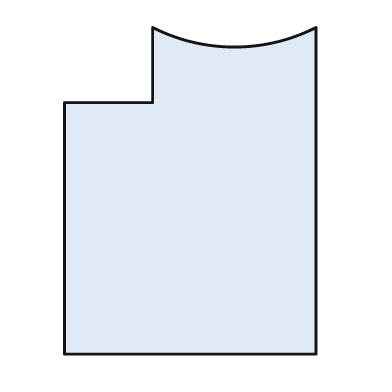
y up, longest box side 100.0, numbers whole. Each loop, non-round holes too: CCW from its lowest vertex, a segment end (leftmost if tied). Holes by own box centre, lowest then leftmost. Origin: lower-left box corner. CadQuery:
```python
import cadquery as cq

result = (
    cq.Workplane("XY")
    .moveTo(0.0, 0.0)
    .lineTo(77.0, 0.0)
    .lineTo(77.0, 100.0)
    .threePointArc((52.0, 94.0), (27.0, 100.0))
    .lineTo(27.0, 77.0)
    .lineTo(0.0, 77.0)
    .close()
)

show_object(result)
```